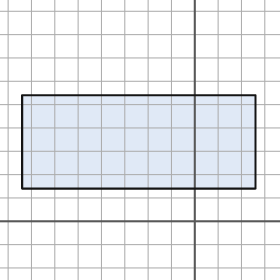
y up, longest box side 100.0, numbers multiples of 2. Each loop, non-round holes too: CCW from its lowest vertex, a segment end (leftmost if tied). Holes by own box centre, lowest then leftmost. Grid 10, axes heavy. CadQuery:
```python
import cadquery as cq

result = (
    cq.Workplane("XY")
    .moveTo(-74.0, 14.0)
    .lineTo(26.0, 14.0)
    .lineTo(26.0, 54.0)
    .lineTo(-74.0, 54.0)
    .close()
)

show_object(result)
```